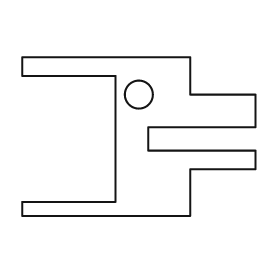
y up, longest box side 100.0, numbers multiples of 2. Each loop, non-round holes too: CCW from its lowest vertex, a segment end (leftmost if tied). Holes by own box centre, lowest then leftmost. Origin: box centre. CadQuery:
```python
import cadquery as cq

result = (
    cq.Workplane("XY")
    .moveTo(-50.0, -34.0)
    .lineTo(22.0, -34.0)
    .lineTo(22.0, -14.0)
    .lineTo(50.0, -14.0)
    .lineTo(50.0, -6.0)
    .lineTo(4.0, -6.0)
    .lineTo(4.0, 4.0)
    .lineTo(50.0, 4.0)
    .lineTo(50.0, 18.0)
    .lineTo(22.0, 18.0)
    .lineTo(22.0, 34.0)
    .lineTo(-50.0, 34.0)
    .lineTo(-50.0, 26.0)
    .lineTo(-10.0, 26.0)
    .lineTo(-10.0, -28.0)
    .lineTo(-50.0, -28.0)
    .close()
    .moveTo(0.0, 18.0)
    .circle(6.0)
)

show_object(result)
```